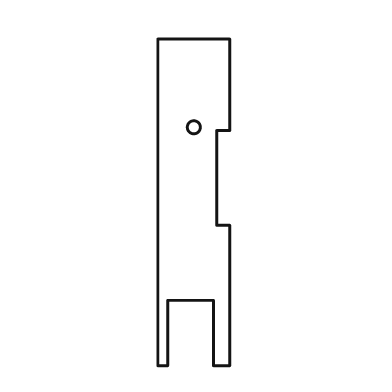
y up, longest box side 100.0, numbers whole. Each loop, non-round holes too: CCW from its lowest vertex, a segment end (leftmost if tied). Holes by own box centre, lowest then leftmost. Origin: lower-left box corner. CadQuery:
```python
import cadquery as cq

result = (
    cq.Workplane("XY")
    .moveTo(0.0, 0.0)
    .lineTo(3.0, 0.0)
    .lineTo(3.0, 20.0)
    .lineTo(17.0, 20.0)
    .lineTo(17.0, 0.0)
    .lineTo(22.0, 0.0)
    .lineTo(22.0, 43.0)
    .lineTo(18.0, 43.0)
    .lineTo(18.0, 72.0)
    .lineTo(22.0, 72.0)
    .lineTo(22.0, 100.0)
    .lineTo(0.0, 100.0)
    .close()
    .moveTo(11.0, 73.0)
    .circle(2.0)
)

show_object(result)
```